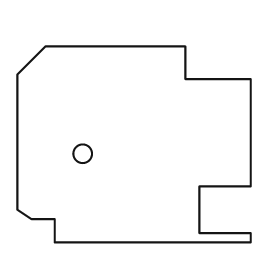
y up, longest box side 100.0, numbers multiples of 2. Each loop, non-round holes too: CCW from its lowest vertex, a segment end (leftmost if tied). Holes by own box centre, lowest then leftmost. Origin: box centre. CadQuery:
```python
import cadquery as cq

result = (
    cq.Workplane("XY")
    .moveTo(-34.0, -42.0)
    .lineTo(50.0, -42.0)
    .lineTo(50.0, -38.0)
    .lineTo(28.0, -38.0)
    .lineTo(28.0, -18.0)
    .lineTo(50.0, -18.0)
    .lineTo(50.0, 28.0)
    .lineTo(22.0, 28.0)
    .lineTo(22.0, 42.0)
    .lineTo(-38.0, 42.0)
    .lineTo(-50.0, 30.0)
    .lineTo(-50.0, -28.0)
    .lineTo(-44.0, -32.0)
    .lineTo(-34.0, -32.0)
    .close()
    .moveTo(-22.0, -4.0)
    .circle(4.0)
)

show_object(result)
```